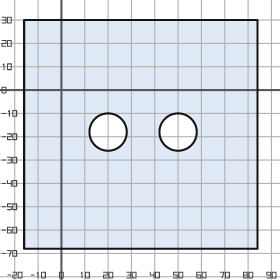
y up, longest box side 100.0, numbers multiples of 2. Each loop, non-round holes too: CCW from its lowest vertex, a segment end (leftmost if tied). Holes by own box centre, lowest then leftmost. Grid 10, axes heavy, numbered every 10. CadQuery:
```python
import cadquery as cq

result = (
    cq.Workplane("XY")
    .moveTo(-16.0, -68.0)
    .lineTo(84.0, -68.0)
    .lineTo(84.0, 30.0)
    .lineTo(-16.0, 30.0)
    .close()
    .moveTo(20.0, -18.0)
    .circle(8.0)
    .moveTo(50.0, -18.0)
    .circle(8.0)
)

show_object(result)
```